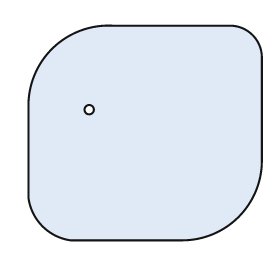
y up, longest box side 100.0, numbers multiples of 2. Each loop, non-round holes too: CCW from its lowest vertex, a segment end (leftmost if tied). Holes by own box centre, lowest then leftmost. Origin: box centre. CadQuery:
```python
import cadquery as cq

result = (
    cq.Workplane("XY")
    .moveTo(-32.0, -46.0)
    .lineTo(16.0, -46.0)
    .threePointArc((40.0, -36.0), (50.0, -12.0))
    .lineTo(50.0, 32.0)
    .threePointArc((46.0, 42.0), (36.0, 46.0))
    .lineTo(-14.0, 46.0)
    .threePointArc((-40.0, 36.0), (-50.0, 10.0))
    .lineTo(-50.0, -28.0)
    .threePointArc((-44.0, -40.0), (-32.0, -46.0))
    .close()
    .moveTo(-24.0, 10.0)
    .circle(2.0)
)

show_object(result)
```